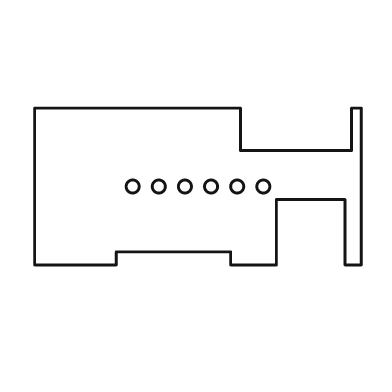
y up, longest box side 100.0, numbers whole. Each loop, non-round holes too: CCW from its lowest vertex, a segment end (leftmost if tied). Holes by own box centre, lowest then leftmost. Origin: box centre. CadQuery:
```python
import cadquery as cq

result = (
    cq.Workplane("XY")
    .moveTo(-50.0, -24.0)
    .lineTo(-25.0, -24.0)
    .lineTo(-25.0, -20.0)
    .lineTo(10.0, -20.0)
    .lineTo(10.0, -24.0)
    .lineTo(24.0, -24.0)
    .lineTo(24.0, -4.0)
    .lineTo(45.0, -4.0)
    .lineTo(45.0, -24.0)
    .lineTo(50.0, -24.0)
    .lineTo(50.0, 24.0)
    .lineTo(47.0, 24.0)
    .lineTo(47.0, 11.0)
    .lineTo(13.0, 11.0)
    .lineTo(13.0, 24.0)
    .lineTo(-50.0, 24.0)
    .close()
    .moveTo(-20.0, 0.0)
    .circle(2.0)
    .moveTo(-12.0, 0.0)
    .circle(2.0)
    .moveTo(-4.0, 0.0)
    .circle(2.0)
    .moveTo(4.0, 0.0)
    .circle(2.0)
    .moveTo(12.0, 0.0)
    .circle(2.0)
    .moveTo(20.0, 0.0)
    .circle(2.0)
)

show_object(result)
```